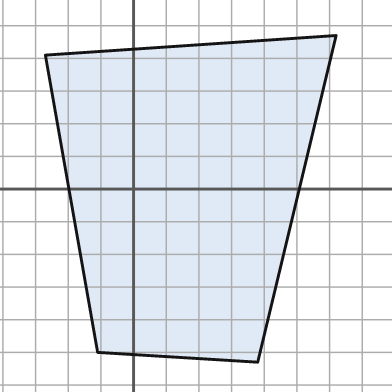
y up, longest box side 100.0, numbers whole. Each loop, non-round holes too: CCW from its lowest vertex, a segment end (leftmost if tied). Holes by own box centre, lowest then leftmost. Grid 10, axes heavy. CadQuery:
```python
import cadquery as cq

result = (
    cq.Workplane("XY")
    .moveTo(38.0, -53.0)
    .lineTo(62.0, 47.0)
    .lineTo(-27.0, 41.0)
    .lineTo(-11.0, -50.0)
    .close()
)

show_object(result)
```